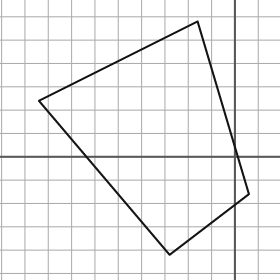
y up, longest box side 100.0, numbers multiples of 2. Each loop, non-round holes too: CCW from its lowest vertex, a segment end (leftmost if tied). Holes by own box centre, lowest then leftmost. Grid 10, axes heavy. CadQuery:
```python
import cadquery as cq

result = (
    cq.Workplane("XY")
    .moveTo(-28.0, -42.0)
    .lineTo(6.0, -16.0)
    .lineTo(-16.0, 58.0)
    .lineTo(-84.0, 24.0)
    .close()
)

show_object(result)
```